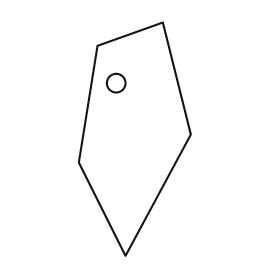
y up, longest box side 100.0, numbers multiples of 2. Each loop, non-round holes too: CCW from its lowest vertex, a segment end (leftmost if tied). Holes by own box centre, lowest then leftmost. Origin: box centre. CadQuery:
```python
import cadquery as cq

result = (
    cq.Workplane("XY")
    .moveTo(-4.0, -50.0)
    .lineTo(24.0, 2.0)
    .lineTo(12.0, 50.0)
    .lineTo(-16.0, 40.0)
    .lineTo(-24.0, -10.0)
    .close()
    .moveTo(-8.0, 24.0)
    .circle(4.0)
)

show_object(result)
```